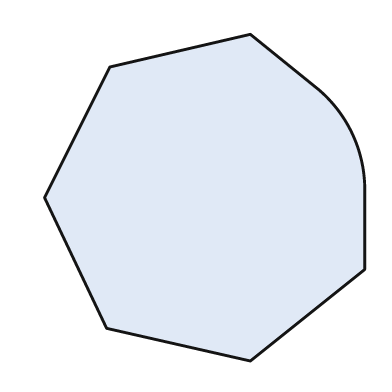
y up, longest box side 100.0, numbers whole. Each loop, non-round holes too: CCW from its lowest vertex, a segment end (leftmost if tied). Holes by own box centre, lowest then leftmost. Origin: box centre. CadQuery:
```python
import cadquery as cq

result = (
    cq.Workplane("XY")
    .moveTo(14.0, -50.0)
    .lineTo(49.0, -22.0)
    .lineTo(49.0, 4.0)
    .threePointArc((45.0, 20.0), (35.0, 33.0))
    .lineTo(14.0, 50.0)
    .lineTo(-29.0, 40.0)
    .lineTo(-49.0, 0.0)
    .lineTo(-30.0, -40.0)
    .close()
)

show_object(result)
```